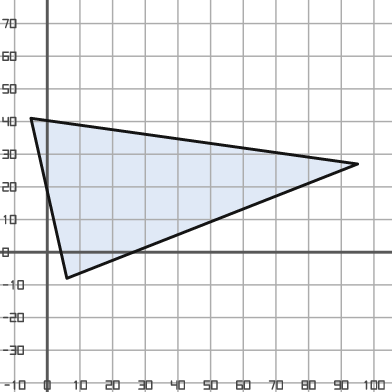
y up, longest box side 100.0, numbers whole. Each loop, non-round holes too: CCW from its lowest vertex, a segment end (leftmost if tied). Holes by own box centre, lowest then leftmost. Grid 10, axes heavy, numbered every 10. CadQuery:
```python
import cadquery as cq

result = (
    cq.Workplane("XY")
    .moveTo(6.0, -8.0)
    .lineTo(95.0, 27.0)
    .lineTo(-5.0, 41.0)
    .close()
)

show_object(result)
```